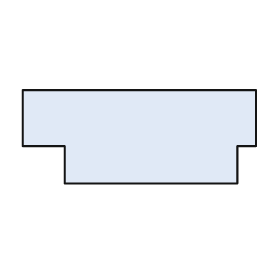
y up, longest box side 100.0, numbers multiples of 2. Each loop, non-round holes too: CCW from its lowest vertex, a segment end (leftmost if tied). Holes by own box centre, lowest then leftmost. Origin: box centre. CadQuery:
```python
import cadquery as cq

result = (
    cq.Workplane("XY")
    .moveTo(-32.0, -20.0)
    .lineTo(42.0, -20.0)
    .lineTo(42.0, -4.0)
    .lineTo(50.0, -4.0)
    .lineTo(50.0, 20.0)
    .lineTo(-50.0, 20.0)
    .lineTo(-50.0, -4.0)
    .lineTo(-32.0, -4.0)
    .close()
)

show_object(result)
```